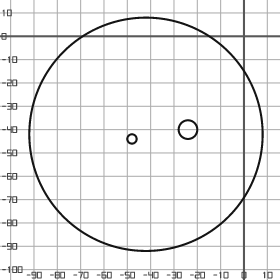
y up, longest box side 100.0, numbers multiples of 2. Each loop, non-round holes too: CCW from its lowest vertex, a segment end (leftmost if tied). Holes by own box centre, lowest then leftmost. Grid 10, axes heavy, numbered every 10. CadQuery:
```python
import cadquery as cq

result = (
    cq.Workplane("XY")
    .moveTo(-42.0, -42.0)
    .circle(50.0)
    .moveTo(-48.0, -44.0)
    .circle(2.0)
    .moveTo(-24.0, -40.0)
    .circle(4.0)
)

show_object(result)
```